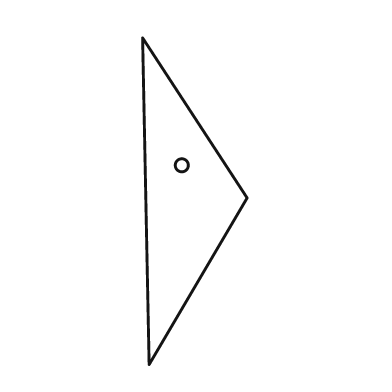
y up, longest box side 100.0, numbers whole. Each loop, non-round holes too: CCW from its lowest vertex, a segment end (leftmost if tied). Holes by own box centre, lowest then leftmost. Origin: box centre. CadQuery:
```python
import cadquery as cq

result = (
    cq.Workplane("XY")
    .moveTo(-14.0, -50.0)
    .lineTo(16.0, 1.0)
    .lineTo(-16.0, 50.0)
    .close()
    .moveTo(-4.0, 11.0)
    .circle(2.0)
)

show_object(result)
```